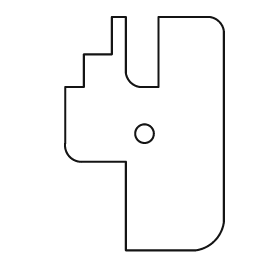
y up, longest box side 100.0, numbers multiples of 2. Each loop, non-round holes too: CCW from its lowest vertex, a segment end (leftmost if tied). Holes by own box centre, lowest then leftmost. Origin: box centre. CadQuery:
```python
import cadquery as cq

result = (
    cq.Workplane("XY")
    .moveTo(-8.0, -50.0)
    .lineTo(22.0, -50.0)
    .threePointArc((30.0, -46.0), (34.0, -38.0))
    .lineTo(34.0, 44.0)
    .threePointArc((32.0, 48.0), (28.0, 50.0))
    .lineTo(6.0, 50.0)
    .lineTo(6.0, 20.0)
    .lineTo(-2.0, 20.0)
    .threePointArc((-6.0, 22.0), (-8.0, 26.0))
    .lineTo(-8.0, 50.0)
    .lineTo(-14.0, 50.0)
    .lineTo(-14.0, 34.0)
    .lineTo(-26.0, 34.0)
    .lineTo(-26.0, 20.0)
    .lineTo(-34.0, 20.0)
    .lineTo(-34.0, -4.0)
    .threePointArc((-32.0, -10.0), (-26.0, -12.0))
    .lineTo(-8.0, -12.0)
    .close()
    .moveTo(0.0, 0.0)
    .circle(4.0)
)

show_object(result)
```